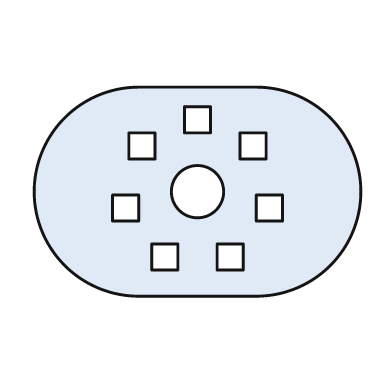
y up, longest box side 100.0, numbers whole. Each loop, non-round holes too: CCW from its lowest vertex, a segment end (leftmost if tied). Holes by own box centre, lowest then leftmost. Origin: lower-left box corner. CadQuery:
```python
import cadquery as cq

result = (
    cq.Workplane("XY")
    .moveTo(32.0, 0.0)
    .lineTo(68.0, 0.0)
    .threePointArc((100.0, 32.0), (68.0, 64.0))
    .lineTo(32.0, 64.0)
    .threePointArc((0.0, 32.0), (32.0, 0.0))
    .close()
    .moveTo(36.0, 8.0)
    .lineTo(44.0, 8.0)
    .lineTo(44.0, 16.0)
    .lineTo(36.0, 16.0)
    .close()
    .moveTo(56.0, 8.0)
    .lineTo(64.0, 8.0)
    .lineTo(64.0, 16.0)
    .lineTo(56.0, 16.0)
    .close()
    .moveTo(24.0, 23.0)
    .lineTo(32.0, 23.0)
    .lineTo(32.0, 31.0)
    .lineTo(24.0, 31.0)
    .close()
    .moveTo(68.0, 23.0)
    .lineTo(76.0, 23.0)
    .lineTo(76.0, 31.0)
    .lineTo(68.0, 31.0)
    .close()
    .moveTo(50.0, 32.0)
    .circle(8.0)
    .moveTo(29.0, 42.0)
    .lineTo(37.0, 42.0)
    .lineTo(37.0, 50.0)
    .lineTo(29.0, 50.0)
    .close()
    .moveTo(63.0, 42.0)
    .lineTo(71.0, 42.0)
    .lineTo(71.0, 50.0)
    .lineTo(63.0, 50.0)
    .close()
    .moveTo(46.0, 50.0)
    .lineTo(54.0, 50.0)
    .lineTo(54.0, 58.0)
    .lineTo(46.0, 58.0)
    .close()
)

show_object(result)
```